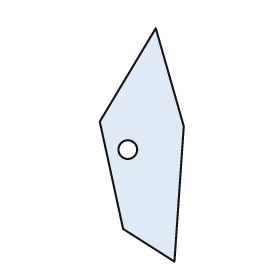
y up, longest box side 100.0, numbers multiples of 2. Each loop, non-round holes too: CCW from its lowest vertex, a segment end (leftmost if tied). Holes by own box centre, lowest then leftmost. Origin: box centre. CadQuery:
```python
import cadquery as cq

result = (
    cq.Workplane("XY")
    .moveTo(14.0, -50.0)
    .lineTo(18.0, 8.0)
    .lineTo(6.0, 50.0)
    .lineTo(-18.0, 10.0)
    .lineTo(-8.0, -36.0)
    .close()
    .moveTo(-6.0, -2.0)
    .circle(4.0)
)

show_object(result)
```